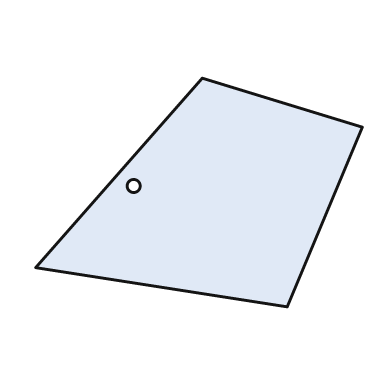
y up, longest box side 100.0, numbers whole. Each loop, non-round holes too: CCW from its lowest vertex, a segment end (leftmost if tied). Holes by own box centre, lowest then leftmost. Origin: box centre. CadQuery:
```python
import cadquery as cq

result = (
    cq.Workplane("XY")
    .moveTo(27.0, -35.0)
    .lineTo(50.0, 20.0)
    .lineTo(1.0, 35.0)
    .lineTo(-50.0, -23.0)
    .close()
    .moveTo(-20.0, 2.0)
    .circle(2.0)
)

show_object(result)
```